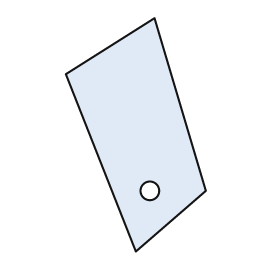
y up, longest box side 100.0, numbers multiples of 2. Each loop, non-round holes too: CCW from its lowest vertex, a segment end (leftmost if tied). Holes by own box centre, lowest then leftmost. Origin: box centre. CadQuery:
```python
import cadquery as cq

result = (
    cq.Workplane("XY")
    .moveTo(0.0, -50.0)
    .lineTo(30.0, -24.0)
    .lineTo(8.0, 50.0)
    .lineTo(-30.0, 26.0)
    .close()
    .moveTo(6.0, -24.0)
    .circle(4.0)
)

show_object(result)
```